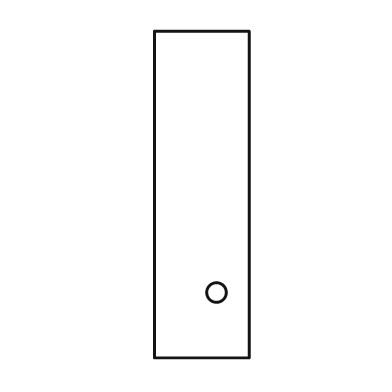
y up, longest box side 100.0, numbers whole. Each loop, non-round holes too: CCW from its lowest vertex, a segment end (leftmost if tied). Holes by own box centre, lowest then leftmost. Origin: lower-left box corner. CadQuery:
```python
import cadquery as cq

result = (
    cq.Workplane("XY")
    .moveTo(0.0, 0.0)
    .lineTo(29.0, 0.0)
    .lineTo(29.0, 100.0)
    .lineTo(0.0, 100.0)
    .close()
    .moveTo(19.0, 20.0)
    .circle(3.0)
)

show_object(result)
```